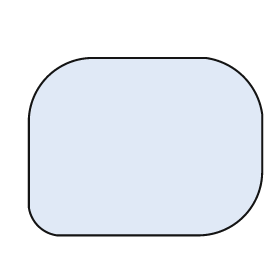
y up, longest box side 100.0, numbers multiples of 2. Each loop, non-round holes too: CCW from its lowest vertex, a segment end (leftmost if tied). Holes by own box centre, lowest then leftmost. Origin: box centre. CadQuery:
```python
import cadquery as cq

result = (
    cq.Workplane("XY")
    .moveTo(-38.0, -38.0)
    .lineTo(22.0, -38.0)
    .threePointArc((42.0, -30.0), (50.0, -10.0))
    .lineTo(50.0, 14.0)
    .threePointArc((42.0, 30.0), (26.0, 38.0))
    .lineTo(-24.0, 38.0)
    .threePointArc((-42.0, 30.0), (-50.0, 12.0))
    .lineTo(-50.0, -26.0)
    .threePointArc((-46.0, -34.0), (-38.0, -38.0))
    .close()
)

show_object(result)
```